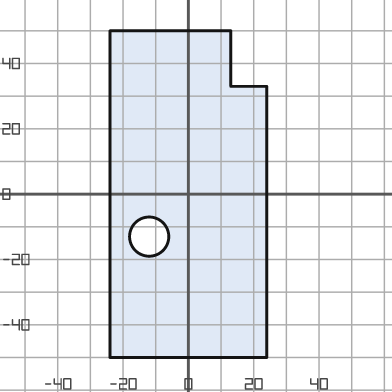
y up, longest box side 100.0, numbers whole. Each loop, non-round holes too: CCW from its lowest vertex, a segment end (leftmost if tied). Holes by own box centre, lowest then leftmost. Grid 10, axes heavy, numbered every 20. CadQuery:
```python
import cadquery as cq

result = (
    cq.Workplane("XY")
    .moveTo(-24.0, -50.0)
    .lineTo(24.0, -50.0)
    .lineTo(24.0, 33.0)
    .lineTo(13.0, 33.0)
    .lineTo(13.0, 50.0)
    .lineTo(-24.0, 50.0)
    .close()
    .moveTo(-12.0, -13.0)
    .circle(6.0)
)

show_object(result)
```